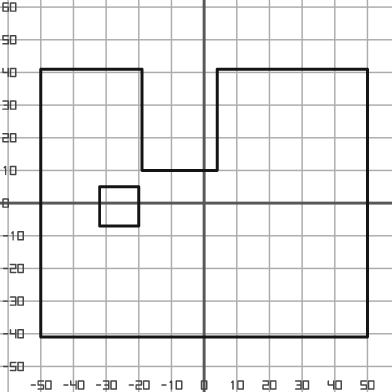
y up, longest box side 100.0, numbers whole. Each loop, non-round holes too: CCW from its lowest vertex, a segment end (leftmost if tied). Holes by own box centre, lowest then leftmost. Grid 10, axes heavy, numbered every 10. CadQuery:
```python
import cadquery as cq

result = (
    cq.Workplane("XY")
    .moveTo(-50.0, -41.0)
    .lineTo(50.0, -41.0)
    .lineTo(50.0, 41.0)
    .lineTo(4.0, 41.0)
    .lineTo(4.0, 10.0)
    .lineTo(-19.0, 10.0)
    .lineTo(-19.0, 41.0)
    .lineTo(-50.0, 41.0)
    .close()
    .moveTo(-32.0, -7.0)
    .lineTo(-20.0, -7.0)
    .lineTo(-20.0, 5.0)
    .lineTo(-32.0, 5.0)
    .close()
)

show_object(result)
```